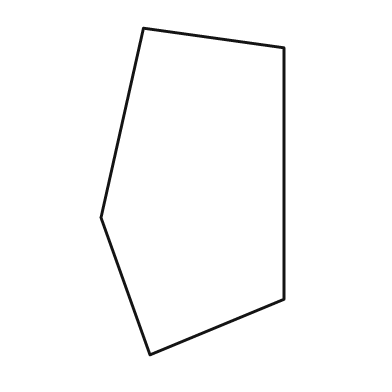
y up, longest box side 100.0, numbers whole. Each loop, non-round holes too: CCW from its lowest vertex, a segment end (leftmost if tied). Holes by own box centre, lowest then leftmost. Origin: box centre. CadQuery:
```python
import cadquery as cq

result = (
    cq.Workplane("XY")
    .moveTo(-13.0, -50.0)
    .lineTo(28.0, -33.0)
    .lineTo(28.0, 44.0)
    .lineTo(-15.0, 50.0)
    .lineTo(-28.0, -8.0)
    .close()
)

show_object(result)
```